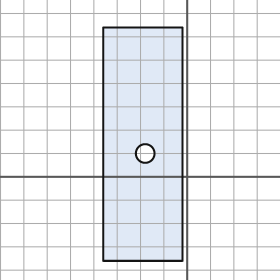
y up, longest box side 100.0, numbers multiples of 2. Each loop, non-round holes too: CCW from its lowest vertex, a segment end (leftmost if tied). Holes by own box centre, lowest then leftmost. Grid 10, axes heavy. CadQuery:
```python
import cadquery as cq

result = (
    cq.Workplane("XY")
    .moveTo(-36.0, -36.0)
    .lineTo(-2.0, -36.0)
    .lineTo(-2.0, 64.0)
    .lineTo(-36.0, 64.0)
    .close()
    .moveTo(-18.0, 10.0)
    .circle(4.0)
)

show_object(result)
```